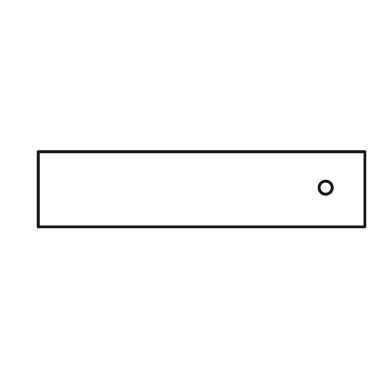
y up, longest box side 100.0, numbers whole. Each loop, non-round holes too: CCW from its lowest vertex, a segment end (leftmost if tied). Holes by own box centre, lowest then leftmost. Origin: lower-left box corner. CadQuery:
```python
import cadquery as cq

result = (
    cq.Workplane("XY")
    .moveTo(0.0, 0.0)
    .lineTo(100.0, 0.0)
    .lineTo(100.0, 23.0)
    .lineTo(0.0, 23.0)
    .close()
    .moveTo(88.0, 12.0)
    .circle(2.0)
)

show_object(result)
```